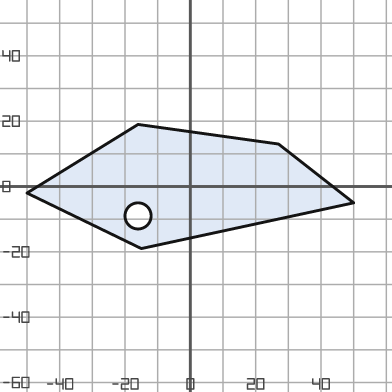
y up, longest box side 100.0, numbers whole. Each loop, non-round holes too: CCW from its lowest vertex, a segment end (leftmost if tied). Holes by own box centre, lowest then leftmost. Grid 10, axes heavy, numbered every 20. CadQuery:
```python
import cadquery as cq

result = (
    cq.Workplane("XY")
    .moveTo(-15.0, -19.0)
    .lineTo(50.0, -5.0)
    .lineTo(27.0, 13.0)
    .lineTo(-16.0, 19.0)
    .lineTo(-50.0, -2.0)
    .close()
    .moveTo(-16.0, -9.0)
    .circle(4.0)
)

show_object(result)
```